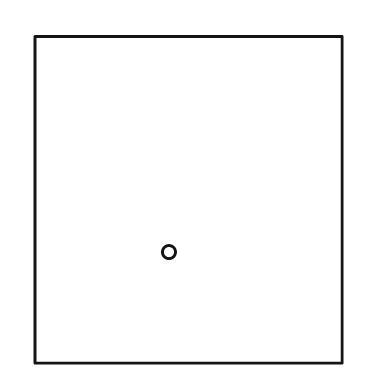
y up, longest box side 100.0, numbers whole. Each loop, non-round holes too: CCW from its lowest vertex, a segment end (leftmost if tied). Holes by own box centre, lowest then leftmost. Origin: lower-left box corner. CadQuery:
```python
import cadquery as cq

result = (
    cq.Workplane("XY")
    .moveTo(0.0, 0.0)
    .lineTo(94.0, 0.0)
    .lineTo(94.0, 100.0)
    .lineTo(0.0, 100.0)
    .close()
    .moveTo(41.0, 34.0)
    .circle(2.0)
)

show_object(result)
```